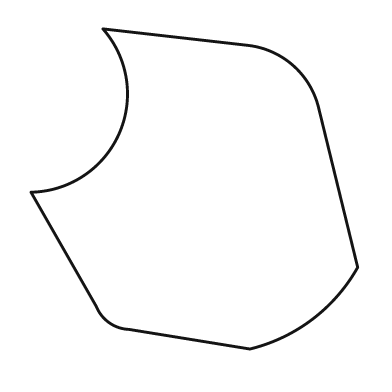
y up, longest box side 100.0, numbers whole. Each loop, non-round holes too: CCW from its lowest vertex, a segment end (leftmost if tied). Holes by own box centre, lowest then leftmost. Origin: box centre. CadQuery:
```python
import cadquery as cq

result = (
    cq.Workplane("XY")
    .moveTo(17.0, -49.0)
    .threePointArc((36.0, -40.0), (50.0, -24.0))
    .lineTo(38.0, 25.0)
    .threePointArc((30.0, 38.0), (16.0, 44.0))
    .lineTo(-28.0, 49.0)
    .threePointArc((-23.0, 17.0), (-50.0, -1.0))
    .lineTo(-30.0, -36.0)
    .threePointArc((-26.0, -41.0), (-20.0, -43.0))
    .close()
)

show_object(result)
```